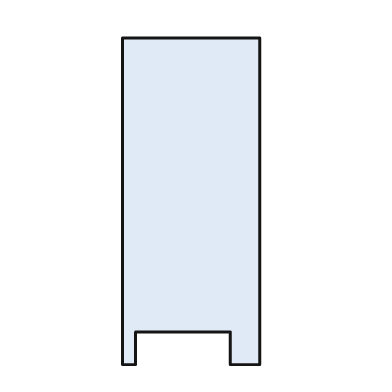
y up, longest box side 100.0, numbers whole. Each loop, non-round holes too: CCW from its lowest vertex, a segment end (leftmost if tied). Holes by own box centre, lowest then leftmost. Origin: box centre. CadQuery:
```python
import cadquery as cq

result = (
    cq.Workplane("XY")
    .moveTo(-21.0, -50.0)
    .lineTo(-17.0, -50.0)
    .lineTo(-17.0, -40.0)
    .lineTo(12.0, -40.0)
    .lineTo(12.0, -50.0)
    .lineTo(21.0, -50.0)
    .lineTo(21.0, 50.0)
    .lineTo(-21.0, 50.0)
    .close()
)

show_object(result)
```